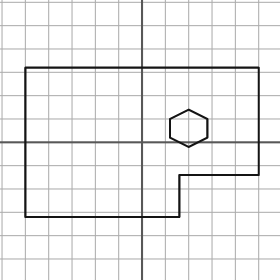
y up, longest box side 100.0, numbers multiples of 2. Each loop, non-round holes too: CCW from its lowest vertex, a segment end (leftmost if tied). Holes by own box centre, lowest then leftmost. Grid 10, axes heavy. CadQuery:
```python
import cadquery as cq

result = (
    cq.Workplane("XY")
    .moveTo(-50.0, -32.0)
    .lineTo(16.0, -32.0)
    .lineTo(16.0, -14.0)
    .lineTo(50.0, -14.0)
    .lineTo(50.0, 32.0)
    .lineTo(-50.0, 32.0)
    .close()
    .moveTo(20.0, -2.0)
    .lineTo(28.0, 2.0)
    .lineTo(28.0, 10.0)
    .lineTo(20.0, 14.0)
    .lineTo(12.0, 10.0)
    .lineTo(12.0, 2.0)
    .close()
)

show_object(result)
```